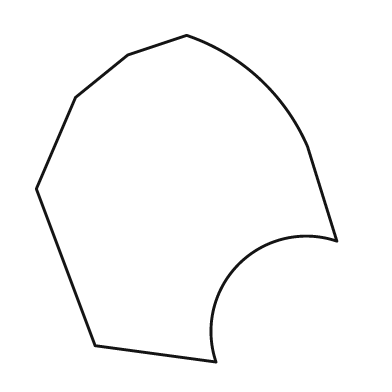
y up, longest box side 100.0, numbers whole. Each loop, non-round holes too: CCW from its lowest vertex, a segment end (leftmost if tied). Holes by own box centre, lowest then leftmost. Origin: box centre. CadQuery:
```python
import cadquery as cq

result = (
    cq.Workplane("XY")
    .moveTo(9.0, -50.0)
    .threePointArc((16.0, -20.0), (46.0, -13.0))
    .lineTo(37.0, 16.0)
    .threePointArc((22.0, 37.0), (0.0, 50.0))
    .lineTo(-18.0, 44.0)
    .lineTo(-34.0, 31.0)
    .lineTo(-46.0, 3.0)
    .lineTo(-28.0, -45.0)
    .close()
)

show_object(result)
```